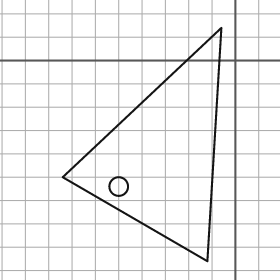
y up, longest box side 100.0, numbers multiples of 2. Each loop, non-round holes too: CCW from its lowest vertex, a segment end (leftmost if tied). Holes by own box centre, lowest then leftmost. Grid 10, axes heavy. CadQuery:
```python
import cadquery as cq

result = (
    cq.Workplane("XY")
    .moveTo(-12.0, -86.0)
    .lineTo(-6.0, 14.0)
    .lineTo(-74.0, -50.0)
    .close()
    .moveTo(-50.0, -54.0)
    .circle(4.0)
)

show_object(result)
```